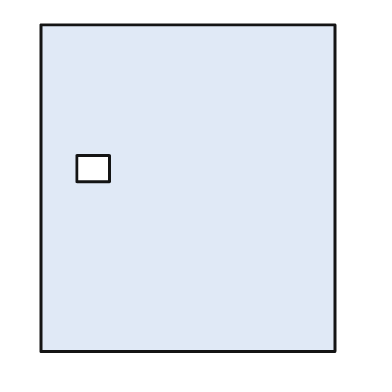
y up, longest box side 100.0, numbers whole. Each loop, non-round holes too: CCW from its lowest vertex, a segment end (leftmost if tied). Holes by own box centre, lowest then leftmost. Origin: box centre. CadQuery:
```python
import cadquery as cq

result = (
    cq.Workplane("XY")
    .moveTo(-45.0, -50.0)
    .lineTo(45.0, -50.0)
    .lineTo(45.0, 50.0)
    .lineTo(-45.0, 50.0)
    .close()
    .moveTo(-34.0, 2.0)
    .lineTo(-24.0, 2.0)
    .lineTo(-24.0, 10.0)
    .lineTo(-34.0, 10.0)
    .close()
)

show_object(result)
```